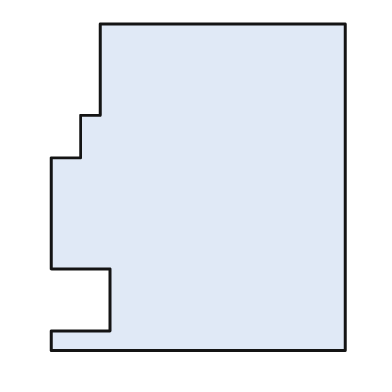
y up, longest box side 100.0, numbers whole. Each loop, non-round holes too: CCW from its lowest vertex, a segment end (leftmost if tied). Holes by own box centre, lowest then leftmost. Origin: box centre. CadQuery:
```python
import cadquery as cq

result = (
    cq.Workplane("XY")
    .moveTo(-45.0, -50.0)
    .lineTo(45.0, -50.0)
    .lineTo(45.0, 50.0)
    .lineTo(-30.0, 50.0)
    .lineTo(-30.0, 22.0)
    .lineTo(-36.0, 22.0)
    .lineTo(-36.0, 9.0)
    .lineTo(-45.0, 9.0)
    .lineTo(-45.0, -25.0)
    .lineTo(-27.0, -25.0)
    .lineTo(-27.0, -44.0)
    .lineTo(-45.0, -44.0)
    .close()
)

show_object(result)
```